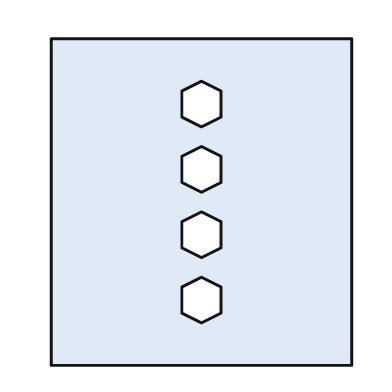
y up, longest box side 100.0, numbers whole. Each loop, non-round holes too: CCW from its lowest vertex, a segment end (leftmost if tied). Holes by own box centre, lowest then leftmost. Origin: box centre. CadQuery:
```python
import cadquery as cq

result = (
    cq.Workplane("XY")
    .moveTo(-46.0, -50.0)
    .lineTo(46.0, -50.0)
    .lineTo(46.0, 50.0)
    .lineTo(-46.0, 50.0)
    .close()
    .moveTo(0.0, -37.0)
    .lineTo(6.0, -34.0)
    .lineTo(6.0, -26.0)
    .lineTo(0.0, -23.0)
    .lineTo(-6.0, -26.0)
    .lineTo(-6.0, -34.0)
    .close()
    .moveTo(0.0, -17.0)
    .lineTo(6.0, -14.0)
    .lineTo(6.0, -6.0)
    .lineTo(0.0, -3.0)
    .lineTo(-6.0, -6.0)
    .lineTo(-6.0, -14.0)
    .close()
    .moveTo(0.0, 3.0)
    .lineTo(6.0, 6.0)
    .lineTo(6.0, 14.0)
    .lineTo(0.0, 17.0)
    .lineTo(-6.0, 14.0)
    .lineTo(-6.0, 6.0)
    .close()
    .moveTo(0.0, 23.0)
    .lineTo(6.0, 26.0)
    .lineTo(6.0, 34.0)
    .lineTo(0.0, 37.0)
    .lineTo(-6.0, 34.0)
    .lineTo(-6.0, 26.0)
    .close()
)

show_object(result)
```